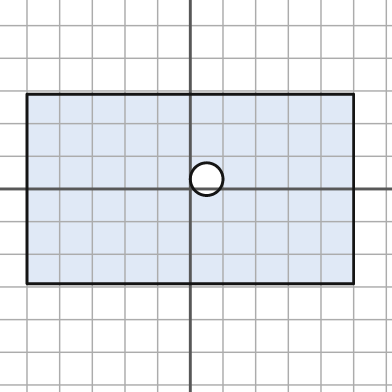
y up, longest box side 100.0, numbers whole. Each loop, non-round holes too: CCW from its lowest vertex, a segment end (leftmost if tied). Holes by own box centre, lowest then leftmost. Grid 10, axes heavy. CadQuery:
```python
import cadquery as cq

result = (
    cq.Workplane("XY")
    .moveTo(-50.0, -29.0)
    .lineTo(50.0, -29.0)
    .lineTo(50.0, 29.0)
    .lineTo(-50.0, 29.0)
    .close()
    .moveTo(5.0, 3.0)
    .circle(5.0)
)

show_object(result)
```